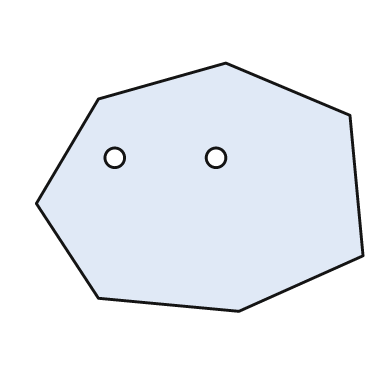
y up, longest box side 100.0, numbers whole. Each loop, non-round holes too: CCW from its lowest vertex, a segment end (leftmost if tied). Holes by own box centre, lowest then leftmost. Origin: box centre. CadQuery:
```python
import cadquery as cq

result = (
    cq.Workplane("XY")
    .moveTo(12.0, -38.0)
    .lineTo(50.0, -21.0)
    .lineTo(46.0, 22.0)
    .lineTo(8.0, 38.0)
    .lineTo(-31.0, 27.0)
    .lineTo(-50.0, -5.0)
    .lineTo(-31.0, -34.0)
    .close()
    .moveTo(-26.0, 9.0)
    .circle(3.0)
    .moveTo(5.0, 9.0)
    .circle(3.0)
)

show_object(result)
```